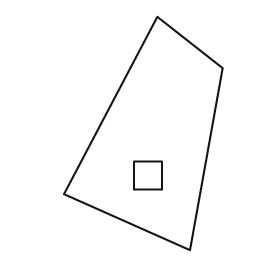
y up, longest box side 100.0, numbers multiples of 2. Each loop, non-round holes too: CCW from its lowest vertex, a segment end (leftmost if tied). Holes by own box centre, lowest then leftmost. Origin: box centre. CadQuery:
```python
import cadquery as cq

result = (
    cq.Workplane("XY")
    .moveTo(20.0, -50.0)
    .lineTo(34.0, 28.0)
    .lineTo(6.0, 50.0)
    .lineTo(-34.0, -26.0)
    .close()
    .moveTo(-4.0, -24.0)
    .lineTo(8.0, -24.0)
    .lineTo(8.0, -12.0)
    .lineTo(-4.0, -12.0)
    .close()
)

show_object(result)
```